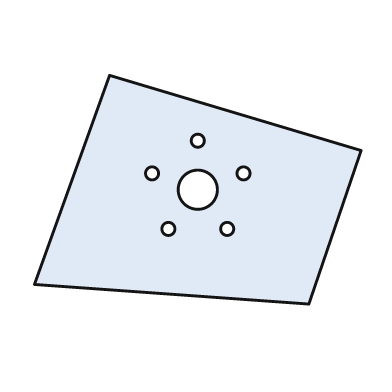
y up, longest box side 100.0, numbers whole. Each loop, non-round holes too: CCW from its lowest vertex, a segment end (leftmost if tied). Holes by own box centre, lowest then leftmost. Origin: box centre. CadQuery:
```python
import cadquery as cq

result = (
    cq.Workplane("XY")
    .moveTo(34.0, -35.0)
    .lineTo(50.0, 12.0)
    .lineTo(-27.0, 35.0)
    .lineTo(-50.0, -29.0)
    .close()
    .moveTo(-9.0, -12.0)
    .circle(2.0)
    .moveTo(9.0, -12.0)
    .circle(2.0)
    .moveTo(0.0, 0.0)
    .circle(6.0)
    .moveTo(-14.0, 5.0)
    .circle(2.0)
    .moveTo(14.0, 5.0)
    .circle(2.0)
    .moveTo(0.0, 15.0)
    .circle(2.0)
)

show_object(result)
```